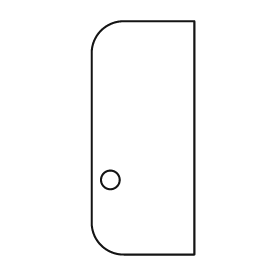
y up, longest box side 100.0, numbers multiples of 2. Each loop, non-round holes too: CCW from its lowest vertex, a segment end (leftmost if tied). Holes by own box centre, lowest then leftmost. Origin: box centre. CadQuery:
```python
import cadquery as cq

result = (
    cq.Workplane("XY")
    .moveTo(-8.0, -50.0)
    .lineTo(22.0, -50.0)
    .lineTo(22.0, 50.0)
    .lineTo(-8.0, 50.0)
    .threePointArc((-18.0, 46.0), (-22.0, 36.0))
    .lineTo(-22.0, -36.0)
    .threePointArc((-18.0, -46.0), (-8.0, -50.0))
    .close()
    .moveTo(-14.0, -18.0)
    .circle(4.0)
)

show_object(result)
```